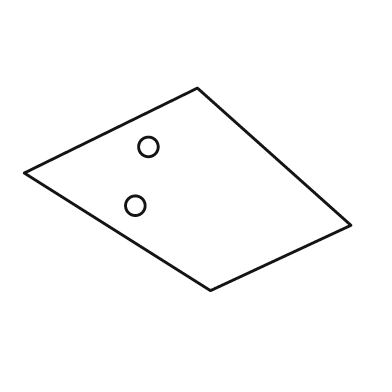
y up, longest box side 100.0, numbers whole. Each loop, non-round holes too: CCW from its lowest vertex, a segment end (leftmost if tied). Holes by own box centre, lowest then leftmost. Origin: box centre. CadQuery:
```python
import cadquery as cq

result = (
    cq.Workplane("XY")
    .moveTo(7.0, -31.0)
    .lineTo(50.0, -11.0)
    .lineTo(3.0, 31.0)
    .lineTo(-50.0, 5.0)
    .close()
    .moveTo(-16.0, -5.0)
    .circle(3.0)
    .moveTo(-12.0, 13.0)
    .circle(3.0)
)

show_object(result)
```